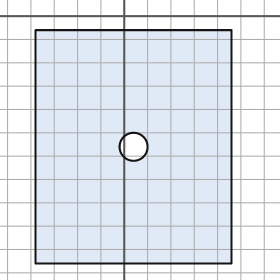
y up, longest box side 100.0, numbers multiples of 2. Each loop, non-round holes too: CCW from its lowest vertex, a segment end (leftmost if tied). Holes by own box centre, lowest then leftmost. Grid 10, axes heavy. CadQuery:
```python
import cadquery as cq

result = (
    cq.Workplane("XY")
    .moveTo(-38.0, -106.0)
    .lineTo(46.0, -106.0)
    .lineTo(46.0, -6.0)
    .lineTo(-38.0, -6.0)
    .close()
    .moveTo(4.0, -56.0)
    .circle(6.0)
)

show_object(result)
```